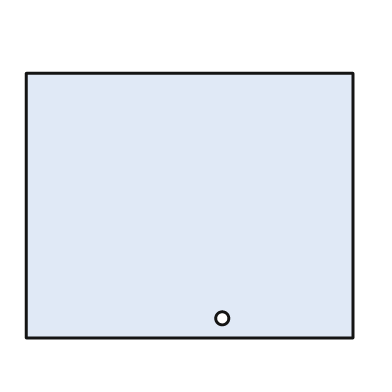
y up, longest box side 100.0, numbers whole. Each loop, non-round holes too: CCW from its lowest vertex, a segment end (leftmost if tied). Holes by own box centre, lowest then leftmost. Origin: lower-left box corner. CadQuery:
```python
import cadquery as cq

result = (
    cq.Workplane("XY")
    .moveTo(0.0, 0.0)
    .lineTo(100.0, 0.0)
    .lineTo(100.0, 81.0)
    .lineTo(0.0, 81.0)
    .close()
    .moveTo(60.0, 6.0)
    .circle(2.0)
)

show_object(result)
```